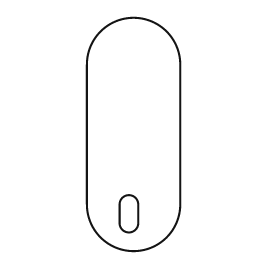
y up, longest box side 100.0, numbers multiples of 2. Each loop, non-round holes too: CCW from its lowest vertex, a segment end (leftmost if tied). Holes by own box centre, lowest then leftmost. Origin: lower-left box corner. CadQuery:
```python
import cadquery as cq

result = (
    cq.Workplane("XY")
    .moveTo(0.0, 20.0)
    .threePointArc((20.0, 0.0), (40.0, 20.0))
    .lineTo(40.0, 80.0)
    .threePointArc((20.0, 100.0), (0.0, 80.0))
    .close()
    .moveTo(14.0, 12.0)
    .threePointArc((18.0, 8.0), (22.0, 12.0))
    .lineTo(22.0, 20.0)
    .threePointArc((18.0, 24.0), (14.0, 20.0))
    .close()
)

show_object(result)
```